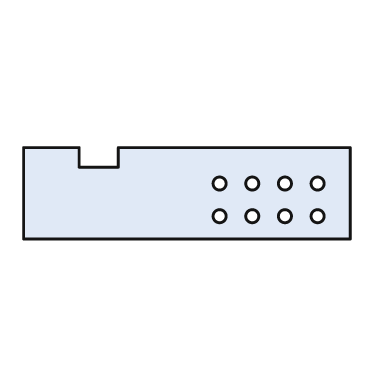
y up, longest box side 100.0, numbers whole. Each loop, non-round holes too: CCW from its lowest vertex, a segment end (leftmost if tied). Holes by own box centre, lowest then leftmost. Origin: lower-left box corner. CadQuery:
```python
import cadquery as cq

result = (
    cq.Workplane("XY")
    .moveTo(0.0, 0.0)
    .lineTo(100.0, 0.0)
    .lineTo(100.0, 28.0)
    .lineTo(29.0, 28.0)
    .lineTo(29.0, 22.0)
    .lineTo(17.0, 22.0)
    .lineTo(17.0, 28.0)
    .lineTo(0.0, 28.0)
    .close()
    .moveTo(60.0, 7.0)
    .circle(2.0)
    .moveTo(70.0, 7.0)
    .circle(2.0)
    .moveTo(80.0, 7.0)
    .circle(2.0)
    .moveTo(90.0, 7.0)
    .circle(2.0)
    .moveTo(60.0, 17.0)
    .circle(2.0)
    .moveTo(70.0, 17.0)
    .circle(2.0)
    .moveTo(80.0, 17.0)
    .circle(2.0)
    .moveTo(90.0, 17.0)
    .circle(2.0)
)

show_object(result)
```